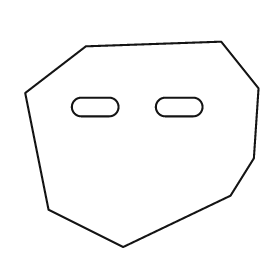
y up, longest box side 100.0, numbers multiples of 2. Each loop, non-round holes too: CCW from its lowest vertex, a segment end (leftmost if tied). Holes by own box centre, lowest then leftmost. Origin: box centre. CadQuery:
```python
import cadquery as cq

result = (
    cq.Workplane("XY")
    .moveTo(-8.0, -44.0)
    .lineTo(38.0, -22.0)
    .lineTo(48.0, -6.0)
    .lineTo(50.0, 24.0)
    .lineTo(34.0, 44.0)
    .lineTo(-24.0, 42.0)
    .lineTo(-50.0, 22.0)
    .lineTo(-40.0, -28.0)
    .close()
    .moveTo(-26.0, 12.0)
    .lineTo(-14.0, 12.0)
    .threePointArc((-10.0, 16.0), (-14.0, 20.0))
    .lineTo(-26.0, 20.0)
    .threePointArc((-30.0, 16.0), (-26.0, 12.0))
    .close()
    .moveTo(10.0, 12.0)
    .lineTo(22.0, 12.0)
    .threePointArc((26.0, 16.0), (22.0, 20.0))
    .lineTo(10.0, 20.0)
    .threePointArc((6.0, 16.0), (10.0, 12.0))
    .close()
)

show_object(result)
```